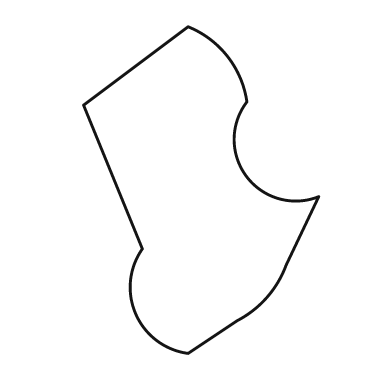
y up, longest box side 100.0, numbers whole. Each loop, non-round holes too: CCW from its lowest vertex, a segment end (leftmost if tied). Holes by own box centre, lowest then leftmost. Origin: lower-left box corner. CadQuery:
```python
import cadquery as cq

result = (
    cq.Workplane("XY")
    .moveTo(32.0, 0.0)
    .lineTo(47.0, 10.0)
    .threePointArc((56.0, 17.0), (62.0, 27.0))
    .lineTo(72.0, 48.0)
    .threePointArc((50.0, 54.0), (50.0, 77.0))
    .threePointArc((44.0, 91.0), (32.0, 100.0))
    .lineTo(0.0, 76.0)
    .lineTo(18.0, 32.0)
    .threePointArc((16.0, 12.0), (32.0, 0.0))
    .close()
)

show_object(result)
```